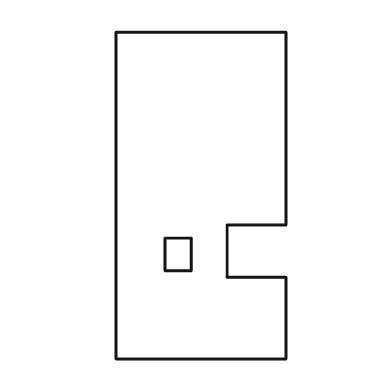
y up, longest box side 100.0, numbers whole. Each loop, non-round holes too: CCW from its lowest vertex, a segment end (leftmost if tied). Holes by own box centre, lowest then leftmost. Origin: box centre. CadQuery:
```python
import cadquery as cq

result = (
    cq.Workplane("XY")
    .moveTo(-26.0, -50.0)
    .lineTo(26.0, -50.0)
    .lineTo(26.0, -25.0)
    .lineTo(8.0, -25.0)
    .lineTo(8.0, -9.0)
    .lineTo(26.0, -9.0)
    .lineTo(26.0, 50.0)
    .lineTo(-26.0, 50.0)
    .close()
    .moveTo(-11.0, -23.0)
    .lineTo(-3.0, -23.0)
    .lineTo(-3.0, -13.0)
    .lineTo(-11.0, -13.0)
    .close()
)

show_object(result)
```